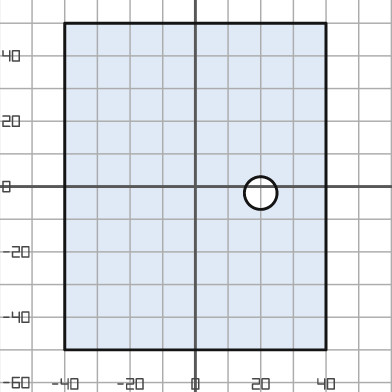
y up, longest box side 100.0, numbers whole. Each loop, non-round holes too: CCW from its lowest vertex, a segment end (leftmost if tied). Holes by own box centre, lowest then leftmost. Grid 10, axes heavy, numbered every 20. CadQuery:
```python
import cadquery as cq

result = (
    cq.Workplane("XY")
    .moveTo(-40.0, -50.0)
    .lineTo(40.0, -50.0)
    .lineTo(40.0, 50.0)
    .lineTo(-40.0, 50.0)
    .close()
    .moveTo(20.0, -2.0)
    .circle(5.0)
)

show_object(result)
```